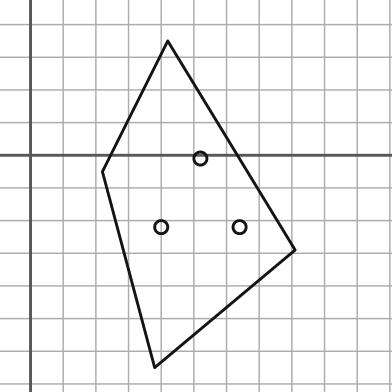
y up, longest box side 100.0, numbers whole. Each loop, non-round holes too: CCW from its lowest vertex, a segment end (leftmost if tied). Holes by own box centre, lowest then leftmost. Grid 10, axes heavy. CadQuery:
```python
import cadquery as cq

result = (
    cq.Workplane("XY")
    .moveTo(38.0, -65.0)
    .lineTo(81.0, -29.0)
    .lineTo(42.0, 35.0)
    .lineTo(22.0, -5.0)
    .close()
    .moveTo(40.0, -22.0)
    .circle(2.0)
    .moveTo(64.0, -22.0)
    .circle(2.0)
    .moveTo(52.0, -1.0)
    .circle(2.0)
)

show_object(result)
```